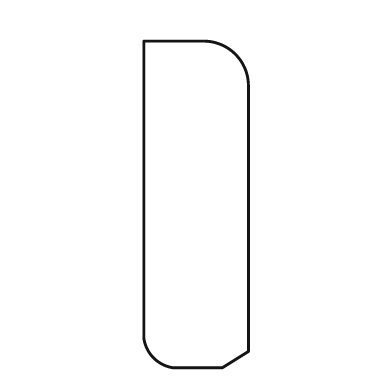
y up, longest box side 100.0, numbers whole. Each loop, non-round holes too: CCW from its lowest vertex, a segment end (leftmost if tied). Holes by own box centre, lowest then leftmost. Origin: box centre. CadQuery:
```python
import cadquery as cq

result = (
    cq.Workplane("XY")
    .moveTo(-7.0, -50.0)
    .lineTo(8.0, -50.0)
    .lineTo(16.0, -45.0)
    .lineTo(16.0, 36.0)
    .threePointArc((12.0, 46.0), (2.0, 50.0))
    .lineTo(-16.0, 50.0)
    .lineTo(-16.0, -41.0)
    .threePointArc((-13.0, -47.0), (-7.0, -50.0))
    .close()
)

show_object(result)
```